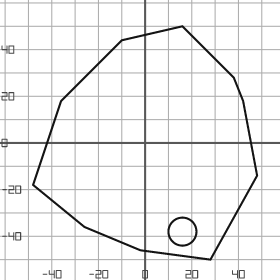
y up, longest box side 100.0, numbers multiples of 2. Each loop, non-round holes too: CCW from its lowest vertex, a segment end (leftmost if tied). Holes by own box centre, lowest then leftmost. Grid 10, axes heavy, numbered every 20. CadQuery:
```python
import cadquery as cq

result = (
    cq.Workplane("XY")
    .moveTo(28.0, -50.0)
    .lineTo(48.0, -14.0)
    .lineTo(42.0, 18.0)
    .lineTo(38.0, 28.0)
    .lineTo(16.0, 50.0)
    .lineTo(-10.0, 44.0)
    .lineTo(-36.0, 18.0)
    .lineTo(-48.0, -18.0)
    .lineTo(-26.0, -36.0)
    .lineTo(-2.0, -46.0)
    .close()
    .moveTo(16.0, -38.0)
    .circle(6.0)
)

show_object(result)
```